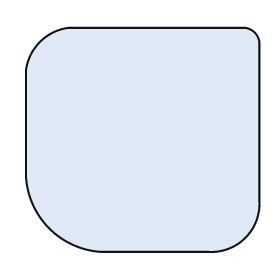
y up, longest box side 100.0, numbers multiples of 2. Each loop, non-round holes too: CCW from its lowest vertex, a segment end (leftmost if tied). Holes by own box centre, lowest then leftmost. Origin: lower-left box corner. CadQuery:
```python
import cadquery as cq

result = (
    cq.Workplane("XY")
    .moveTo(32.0, 0.0)
    .lineTo(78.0, 0.0)
    .threePointArc((94.0, 6.0), (100.0, 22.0))
    .lineTo(100.0, 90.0)
    .threePointArc((98.0, 94.0), (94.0, 96.0))
    .lineTo(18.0, 96.0)
    .threePointArc((6.0, 90.0), (0.0, 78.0))
    .lineTo(0.0, 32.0)
    .threePointArc((10.0, 10.0), (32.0, 0.0))
    .close()
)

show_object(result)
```